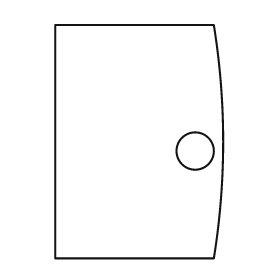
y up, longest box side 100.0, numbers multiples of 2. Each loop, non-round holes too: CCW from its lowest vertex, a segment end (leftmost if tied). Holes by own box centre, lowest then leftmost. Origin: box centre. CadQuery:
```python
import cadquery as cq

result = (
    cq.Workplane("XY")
    .moveTo(-36.0, -50.0)
    .lineTo(32.0, -50.0)
    .threePointArc((36.0, 0.0), (32.0, 50.0))
    .lineTo(-36.0, 50.0)
    .close()
    .moveTo(24.0, -4.0)
    .circle(8.0)
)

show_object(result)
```